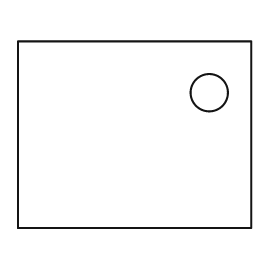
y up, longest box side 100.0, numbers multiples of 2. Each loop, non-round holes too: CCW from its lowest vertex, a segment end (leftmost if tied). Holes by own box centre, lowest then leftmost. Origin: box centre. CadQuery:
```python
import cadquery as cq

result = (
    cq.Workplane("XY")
    .moveTo(-50.0, -40.0)
    .lineTo(50.0, -40.0)
    .lineTo(50.0, 40.0)
    .lineTo(-50.0, 40.0)
    .close()
    .moveTo(32.0, 18.0)
    .circle(8.0)
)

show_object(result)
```